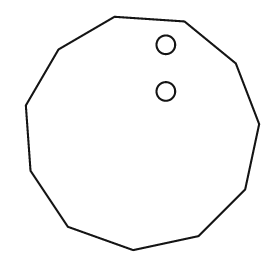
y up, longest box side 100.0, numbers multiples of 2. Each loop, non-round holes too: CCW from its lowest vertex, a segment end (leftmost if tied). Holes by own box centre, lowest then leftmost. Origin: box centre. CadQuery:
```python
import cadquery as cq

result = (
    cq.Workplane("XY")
    .moveTo(-4.0, -50.0)
    .lineTo(24.0, -44.0)
    .lineTo(44.0, -24.0)
    .lineTo(50.0, 4.0)
    .lineTo(40.0, 30.0)
    .lineTo(18.0, 48.0)
    .lineTo(-12.0, 50.0)
    .lineTo(-36.0, 36.0)
    .lineTo(-50.0, 12.0)
    .lineTo(-48.0, -16.0)
    .lineTo(-32.0, -40.0)
    .close()
    .moveTo(10.0, 18.0)
    .circle(4.0)
    .moveTo(10.0, 38.0)
    .circle(4.0)
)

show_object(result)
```